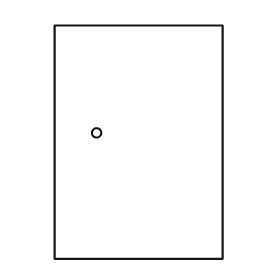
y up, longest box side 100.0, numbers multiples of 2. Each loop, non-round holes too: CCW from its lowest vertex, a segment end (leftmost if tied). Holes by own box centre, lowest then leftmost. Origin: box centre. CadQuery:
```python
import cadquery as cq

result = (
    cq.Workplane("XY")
    .moveTo(-36.0, -50.0)
    .lineTo(36.0, -50.0)
    .lineTo(36.0, 50.0)
    .lineTo(-36.0, 50.0)
    .close()
    .moveTo(-18.0, 4.0)
    .circle(2.0)
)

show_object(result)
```